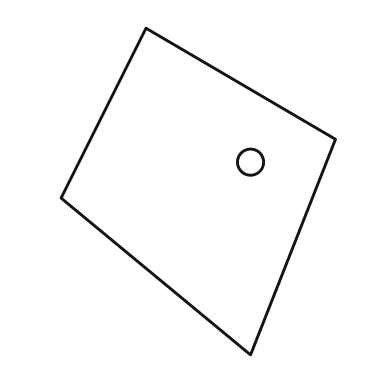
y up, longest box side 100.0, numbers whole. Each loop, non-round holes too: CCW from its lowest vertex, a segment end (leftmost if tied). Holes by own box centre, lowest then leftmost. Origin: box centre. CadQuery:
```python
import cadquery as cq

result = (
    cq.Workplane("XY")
    .moveTo(16.0, -50.0)
    .lineTo(42.0, 16.0)
    .lineTo(-16.0, 50.0)
    .lineTo(-42.0, -2.0)
    .close()
    .moveTo(16.0, 9.0)
    .circle(4.0)
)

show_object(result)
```